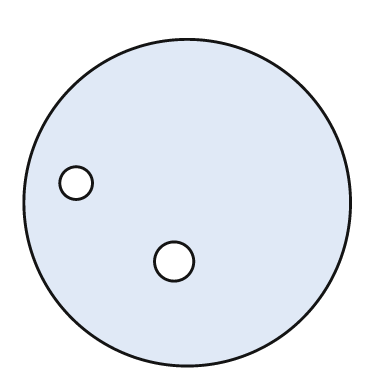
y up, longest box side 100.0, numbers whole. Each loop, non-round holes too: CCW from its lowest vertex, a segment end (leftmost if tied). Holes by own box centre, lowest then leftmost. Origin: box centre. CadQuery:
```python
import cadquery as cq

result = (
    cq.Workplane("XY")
    .moveTo(0.0, 0.0)
    .circle(50.0)
    .moveTo(-4.0, -18.0)
    .circle(6.0)
    .moveTo(-34.0, 6.0)
    .circle(5.0)
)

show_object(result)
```